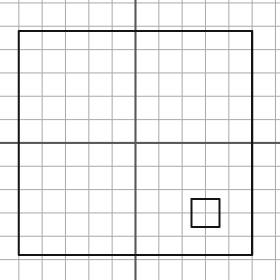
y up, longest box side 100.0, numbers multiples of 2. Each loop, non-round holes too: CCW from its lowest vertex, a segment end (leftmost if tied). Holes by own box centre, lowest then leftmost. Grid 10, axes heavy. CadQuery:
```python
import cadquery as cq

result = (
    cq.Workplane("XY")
    .moveTo(-50.0, -48.0)
    .lineTo(50.0, -48.0)
    .lineTo(50.0, 48.0)
    .lineTo(-50.0, 48.0)
    .close()
    .moveTo(24.0, -36.0)
    .lineTo(36.0, -36.0)
    .lineTo(36.0, -24.0)
    .lineTo(24.0, -24.0)
    .close()
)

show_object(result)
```